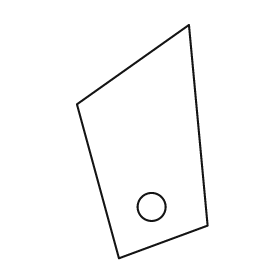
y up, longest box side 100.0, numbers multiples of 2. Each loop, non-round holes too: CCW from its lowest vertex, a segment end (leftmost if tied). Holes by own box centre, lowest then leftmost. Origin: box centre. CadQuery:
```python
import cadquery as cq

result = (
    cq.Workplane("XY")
    .moveTo(-10.0, -50.0)
    .lineTo(28.0, -36.0)
    .lineTo(20.0, 50.0)
    .lineTo(-28.0, 16.0)
    .close()
    .moveTo(4.0, -28.0)
    .circle(6.0)
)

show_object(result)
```